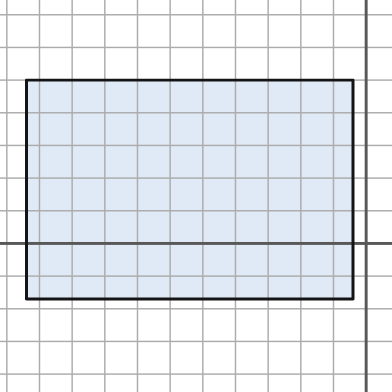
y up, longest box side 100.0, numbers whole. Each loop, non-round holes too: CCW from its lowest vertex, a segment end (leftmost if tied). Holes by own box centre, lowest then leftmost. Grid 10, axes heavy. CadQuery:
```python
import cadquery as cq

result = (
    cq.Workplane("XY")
    .moveTo(-104.0, -17.0)
    .lineTo(-4.0, -17.0)
    .lineTo(-4.0, 50.0)
    .lineTo(-104.0, 50.0)
    .close()
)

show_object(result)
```